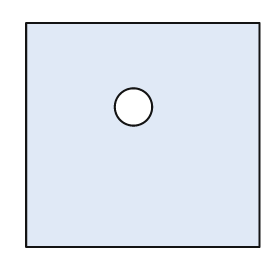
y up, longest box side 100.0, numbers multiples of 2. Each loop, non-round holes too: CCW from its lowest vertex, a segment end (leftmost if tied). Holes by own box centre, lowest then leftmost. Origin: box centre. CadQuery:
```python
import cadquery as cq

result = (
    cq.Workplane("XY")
    .moveTo(-50.0, -48.0)
    .lineTo(50.0, -48.0)
    .lineTo(50.0, 48.0)
    .lineTo(-50.0, 48.0)
    .close()
    .moveTo(-4.0, 12.0)
    .circle(8.0)
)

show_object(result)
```